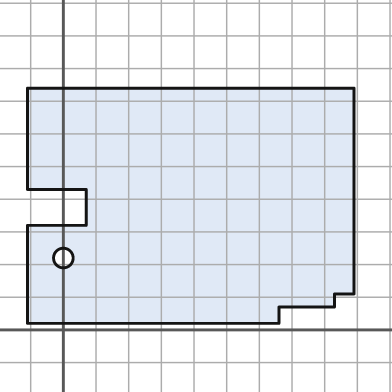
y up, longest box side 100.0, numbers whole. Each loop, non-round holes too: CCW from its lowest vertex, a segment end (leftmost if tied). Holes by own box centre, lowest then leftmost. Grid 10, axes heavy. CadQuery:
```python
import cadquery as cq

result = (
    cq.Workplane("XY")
    .moveTo(-11.0, 2.0)
    .lineTo(66.0, 2.0)
    .lineTo(66.0, 7.0)
    .lineTo(83.0, 7.0)
    .lineTo(83.0, 11.0)
    .lineTo(89.0, 11.0)
    .lineTo(89.0, 74.0)
    .lineTo(-11.0, 74.0)
    .lineTo(-11.0, 43.0)
    .lineTo(7.0, 43.0)
    .lineTo(7.0, 32.0)
    .lineTo(-11.0, 32.0)
    .close()
    .moveTo(0.0, 22.0)
    .circle(3.0)
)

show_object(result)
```